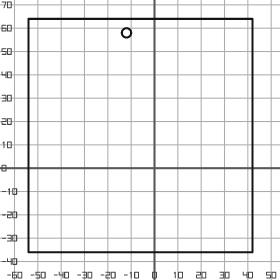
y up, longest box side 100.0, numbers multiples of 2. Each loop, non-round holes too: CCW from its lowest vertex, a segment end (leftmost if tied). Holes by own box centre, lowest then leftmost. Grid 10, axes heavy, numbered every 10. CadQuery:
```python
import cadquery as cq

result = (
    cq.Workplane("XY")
    .moveTo(-54.0, -36.0)
    .lineTo(42.0, -36.0)
    .lineTo(42.0, 64.0)
    .lineTo(-54.0, 64.0)
    .close()
    .moveTo(-12.0, 58.0)
    .circle(2.0)
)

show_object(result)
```